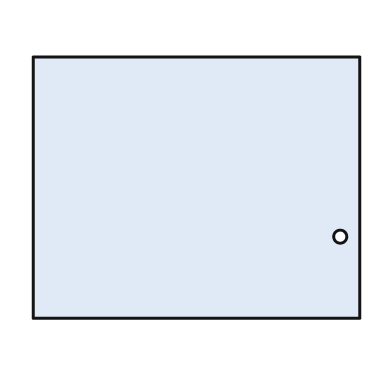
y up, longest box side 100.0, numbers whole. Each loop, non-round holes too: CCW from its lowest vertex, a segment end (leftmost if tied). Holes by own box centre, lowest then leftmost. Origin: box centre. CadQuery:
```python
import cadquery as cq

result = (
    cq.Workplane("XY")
    .moveTo(-50.0, -40.0)
    .lineTo(50.0, -40.0)
    .lineTo(50.0, 40.0)
    .lineTo(-50.0, 40.0)
    .close()
    .moveTo(44.0, -15.0)
    .circle(2.0)
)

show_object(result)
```